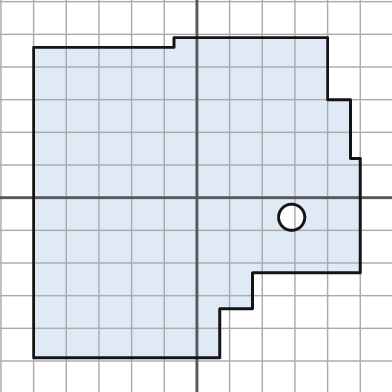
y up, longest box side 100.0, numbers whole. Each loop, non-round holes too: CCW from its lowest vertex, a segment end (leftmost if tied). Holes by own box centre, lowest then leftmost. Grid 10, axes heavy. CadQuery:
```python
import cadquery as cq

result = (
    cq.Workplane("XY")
    .moveTo(-50.0, -49.0)
    .lineTo(7.0, -49.0)
    .lineTo(7.0, -34.0)
    .lineTo(17.0, -34.0)
    .lineTo(17.0, -23.0)
    .lineTo(50.0, -23.0)
    .lineTo(50.0, 12.0)
    .lineTo(47.0, 12.0)
    .lineTo(47.0, 30.0)
    .lineTo(40.0, 30.0)
    .lineTo(40.0, 49.0)
    .lineTo(-7.0, 49.0)
    .lineTo(-7.0, 46.0)
    .lineTo(-50.0, 46.0)
    .close()
    .moveTo(29.0, -6.0)
    .circle(4.0)
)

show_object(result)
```